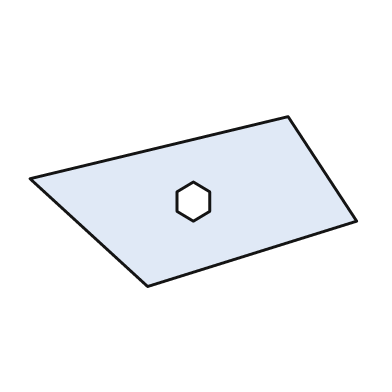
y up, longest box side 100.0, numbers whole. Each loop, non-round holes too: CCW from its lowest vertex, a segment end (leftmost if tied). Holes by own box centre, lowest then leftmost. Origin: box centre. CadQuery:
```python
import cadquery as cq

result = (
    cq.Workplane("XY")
    .moveTo(-14.0, -26.0)
    .lineTo(50.0, -6.0)
    .lineTo(29.0, 26.0)
    .lineTo(-50.0, 7.0)
    .close()
    .moveTo(0.0, -6.0)
    .lineTo(5.0, -3.0)
    .lineTo(5.0, 3.0)
    .lineTo(0.0, 6.0)
    .lineTo(-5.0, 3.0)
    .lineTo(-5.0, -3.0)
    .close()
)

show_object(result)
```